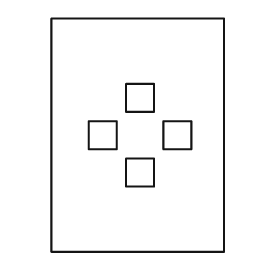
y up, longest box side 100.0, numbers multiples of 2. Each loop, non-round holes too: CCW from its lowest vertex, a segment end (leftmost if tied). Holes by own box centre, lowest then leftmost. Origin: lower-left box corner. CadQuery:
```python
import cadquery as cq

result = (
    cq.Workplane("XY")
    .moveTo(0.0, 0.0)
    .lineTo(74.0, 0.0)
    .lineTo(74.0, 100.0)
    .lineTo(0.0, 100.0)
    .close()
    .moveTo(32.0, 28.0)
    .lineTo(44.0, 28.0)
    .lineTo(44.0, 40.0)
    .lineTo(32.0, 40.0)
    .close()
    .moveTo(16.0, 44.0)
    .lineTo(28.0, 44.0)
    .lineTo(28.0, 56.0)
    .lineTo(16.0, 56.0)
    .close()
    .moveTo(48.0, 44.0)
    .lineTo(60.0, 44.0)
    .lineTo(60.0, 56.0)
    .lineTo(48.0, 56.0)
    .close()
    .moveTo(32.0, 60.0)
    .lineTo(44.0, 60.0)
    .lineTo(44.0, 72.0)
    .lineTo(32.0, 72.0)
    .close()
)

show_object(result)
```